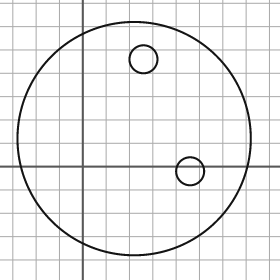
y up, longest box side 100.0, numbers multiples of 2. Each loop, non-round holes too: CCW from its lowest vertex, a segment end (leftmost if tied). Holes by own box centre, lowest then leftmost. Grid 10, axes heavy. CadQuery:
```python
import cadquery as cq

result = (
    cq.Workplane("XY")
    .moveTo(22.0, 12.0)
    .circle(50.0)
    .moveTo(46.0, -2.0)
    .circle(6.0)
    .moveTo(26.0, 46.0)
    .circle(6.0)
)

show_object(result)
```